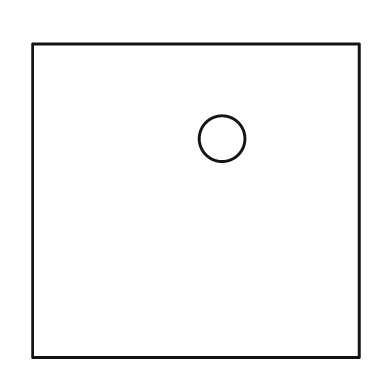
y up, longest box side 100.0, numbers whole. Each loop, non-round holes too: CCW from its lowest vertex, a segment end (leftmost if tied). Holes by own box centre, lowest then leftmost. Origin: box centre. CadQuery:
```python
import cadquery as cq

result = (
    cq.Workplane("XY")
    .moveTo(-50.0, -48.0)
    .lineTo(50.0, -48.0)
    .lineTo(50.0, 48.0)
    .lineTo(-50.0, 48.0)
    .close()
    .moveTo(8.0, 19.0)
    .circle(7.0)
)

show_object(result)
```